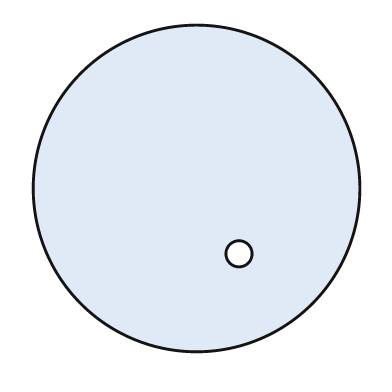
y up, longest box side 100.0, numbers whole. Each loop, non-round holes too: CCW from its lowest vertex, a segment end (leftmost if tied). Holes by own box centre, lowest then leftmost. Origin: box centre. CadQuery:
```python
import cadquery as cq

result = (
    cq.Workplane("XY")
    .moveTo(0.0, 0.0)
    .circle(50.0)
    .moveTo(13.0, -20.0)
    .circle(4.0)
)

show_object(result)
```